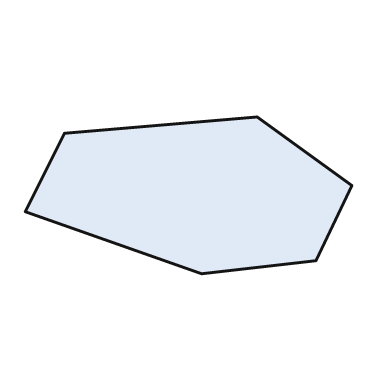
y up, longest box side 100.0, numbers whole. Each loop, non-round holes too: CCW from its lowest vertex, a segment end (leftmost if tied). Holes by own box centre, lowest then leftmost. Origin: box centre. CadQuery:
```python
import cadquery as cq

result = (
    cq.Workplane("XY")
    .moveTo(4.0, -24.0)
    .lineTo(39.0, -20.0)
    .lineTo(50.0, 3.0)
    .lineTo(21.0, 24.0)
    .lineTo(-38.0, 19.0)
    .lineTo(-50.0, -5.0)
    .close()
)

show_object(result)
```